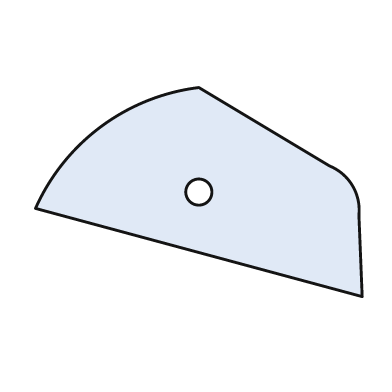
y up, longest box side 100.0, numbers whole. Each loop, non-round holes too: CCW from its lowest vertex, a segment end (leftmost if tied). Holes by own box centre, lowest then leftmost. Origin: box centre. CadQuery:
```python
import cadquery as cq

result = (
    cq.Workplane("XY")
    .moveTo(50.0, -32.0)
    .lineTo(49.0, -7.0)
    .threePointArc((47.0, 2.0), (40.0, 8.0))
    .lineTo(0.0, 32.0)
    .threePointArc((-30.0, 20.0), (-50.0, -5.0))
    .close()
    .moveTo(0.0, 0.0)
    .circle(4.0)
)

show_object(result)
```